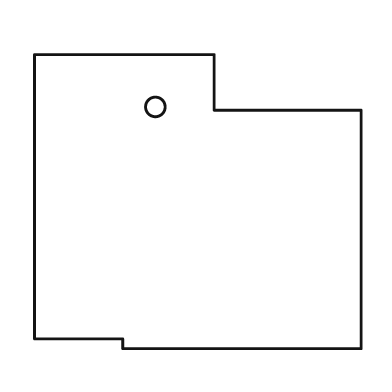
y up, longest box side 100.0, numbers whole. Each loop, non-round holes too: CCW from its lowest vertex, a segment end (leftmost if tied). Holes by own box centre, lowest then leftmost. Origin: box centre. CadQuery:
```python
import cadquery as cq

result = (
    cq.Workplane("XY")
    .moveTo(-23.0, -45.0)
    .lineTo(50.0, -45.0)
    .lineTo(50.0, 28.0)
    .lineTo(5.0, 28.0)
    .lineTo(5.0, 45.0)
    .lineTo(-50.0, 45.0)
    .lineTo(-50.0, -42.0)
    .lineTo(-23.0, -42.0)
    .close()
    .moveTo(-13.0, 29.0)
    .circle(3.0)
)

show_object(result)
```